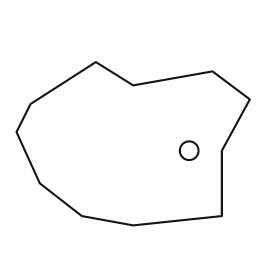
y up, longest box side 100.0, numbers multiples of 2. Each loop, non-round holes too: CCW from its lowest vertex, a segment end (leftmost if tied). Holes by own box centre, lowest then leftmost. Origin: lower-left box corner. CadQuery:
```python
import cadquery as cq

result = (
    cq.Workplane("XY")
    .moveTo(50.0, 0.0)
    .lineTo(88.0, 4.0)
    .lineTo(88.0, 32.0)
    .lineTo(100.0, 54.0)
    .lineTo(84.0, 66.0)
    .lineTo(50.0, 60.0)
    .lineTo(34.0, 70.0)
    .lineTo(6.0, 52.0)
    .lineTo(0.0, 40.0)
    .lineTo(10.0, 18.0)
    .lineTo(28.0, 4.0)
    .close()
    .moveTo(74.0, 32.0)
    .circle(4.0)
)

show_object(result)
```